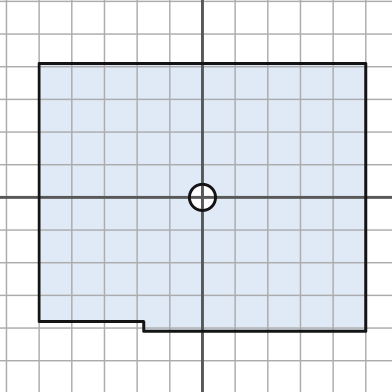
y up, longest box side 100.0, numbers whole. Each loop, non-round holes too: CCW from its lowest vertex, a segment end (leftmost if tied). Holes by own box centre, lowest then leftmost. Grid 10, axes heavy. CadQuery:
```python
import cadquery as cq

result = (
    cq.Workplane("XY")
    .moveTo(-18.0, -41.0)
    .lineTo(50.0, -41.0)
    .lineTo(50.0, 41.0)
    .lineTo(-50.0, 41.0)
    .lineTo(-50.0, -38.0)
    .lineTo(-18.0, -38.0)
    .close()
    .moveTo(0.0, 0.0)
    .circle(4.0)
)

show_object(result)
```